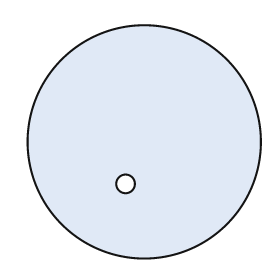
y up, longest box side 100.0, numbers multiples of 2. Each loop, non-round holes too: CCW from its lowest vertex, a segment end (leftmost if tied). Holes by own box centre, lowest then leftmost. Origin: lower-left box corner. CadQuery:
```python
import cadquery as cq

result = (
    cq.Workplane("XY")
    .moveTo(50.0, 50.0)
    .circle(50.0)
    .moveTo(42.0, 32.0)
    .circle(4.0)
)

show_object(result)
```